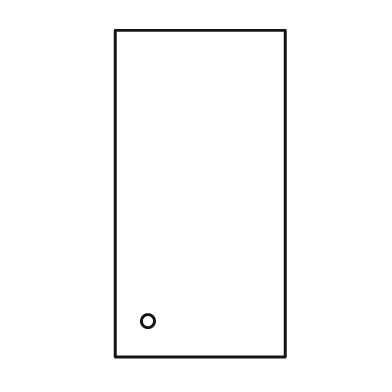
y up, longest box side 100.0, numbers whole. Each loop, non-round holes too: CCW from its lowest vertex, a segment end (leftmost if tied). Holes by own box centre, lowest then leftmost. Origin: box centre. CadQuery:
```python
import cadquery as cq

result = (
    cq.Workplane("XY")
    .moveTo(-26.0, -50.0)
    .lineTo(26.0, -50.0)
    .lineTo(26.0, 50.0)
    .lineTo(-26.0, 50.0)
    .close()
    .moveTo(-16.0, -39.0)
    .circle(2.0)
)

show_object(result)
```